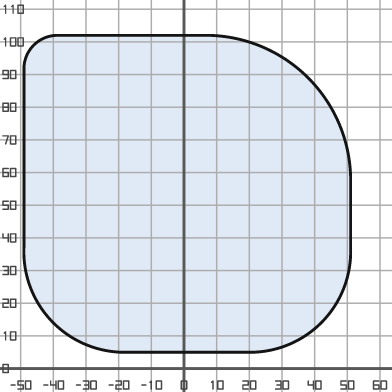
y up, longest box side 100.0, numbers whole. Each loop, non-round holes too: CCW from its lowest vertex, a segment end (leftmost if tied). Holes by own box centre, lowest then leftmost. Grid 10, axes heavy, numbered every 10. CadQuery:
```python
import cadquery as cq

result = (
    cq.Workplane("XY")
    .moveTo(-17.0, 5.0)
    .lineTo(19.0, 5.0)
    .threePointArc((42.0, 14.0), (51.0, 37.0))
    .lineTo(51.0, 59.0)
    .threePointArc((38.0, 89.0), (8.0, 102.0))
    .lineTo(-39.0, 102.0)
    .threePointArc((-46.0, 99.0), (-49.0, 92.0))
    .lineTo(-49.0, 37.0)
    .threePointArc((-40.0, 14.0), (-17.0, 5.0))
    .close()
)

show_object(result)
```